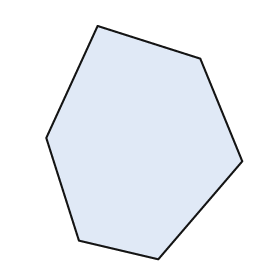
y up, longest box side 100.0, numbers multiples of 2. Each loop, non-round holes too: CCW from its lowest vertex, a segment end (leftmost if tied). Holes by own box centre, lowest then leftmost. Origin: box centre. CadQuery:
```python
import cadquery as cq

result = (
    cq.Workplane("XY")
    .moveTo(6.0, -50.0)
    .lineTo(42.0, -8.0)
    .lineTo(24.0, 36.0)
    .lineTo(-20.0, 50.0)
    .lineTo(-42.0, 2.0)
    .lineTo(-28.0, -42.0)
    .close()
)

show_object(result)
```